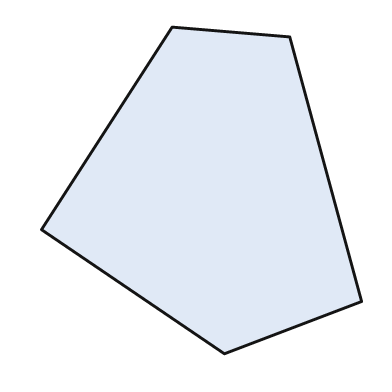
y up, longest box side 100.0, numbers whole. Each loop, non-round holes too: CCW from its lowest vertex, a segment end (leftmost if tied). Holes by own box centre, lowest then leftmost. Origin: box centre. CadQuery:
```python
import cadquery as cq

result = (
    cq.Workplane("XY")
    .moveTo(7.0, -50.0)
    .lineTo(49.0, -34.0)
    .lineTo(27.0, 47.0)
    .lineTo(-9.0, 50.0)
    .lineTo(-49.0, -12.0)
    .close()
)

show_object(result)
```